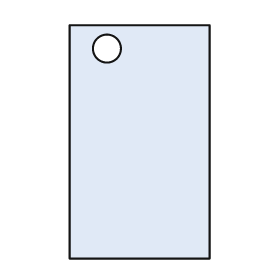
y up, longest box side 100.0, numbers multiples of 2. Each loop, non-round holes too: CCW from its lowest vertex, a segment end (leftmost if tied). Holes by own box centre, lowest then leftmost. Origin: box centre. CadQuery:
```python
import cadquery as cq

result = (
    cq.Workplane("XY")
    .moveTo(-30.0, -50.0)
    .lineTo(30.0, -50.0)
    .lineTo(30.0, 50.0)
    .lineTo(-30.0, 50.0)
    .close()
    .moveTo(-14.0, 40.0)
    .circle(6.0)
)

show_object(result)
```